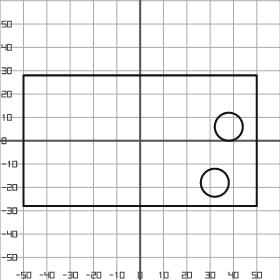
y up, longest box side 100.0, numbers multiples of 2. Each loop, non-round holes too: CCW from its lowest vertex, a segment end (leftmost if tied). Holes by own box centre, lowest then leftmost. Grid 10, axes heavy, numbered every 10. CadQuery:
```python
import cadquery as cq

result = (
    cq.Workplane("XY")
    .moveTo(-50.0, -28.0)
    .lineTo(50.0, -28.0)
    .lineTo(50.0, 28.0)
    .lineTo(-50.0, 28.0)
    .close()
    .moveTo(32.0, -18.0)
    .circle(6.0)
    .moveTo(38.0, 6.0)
    .circle(6.0)
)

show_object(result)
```